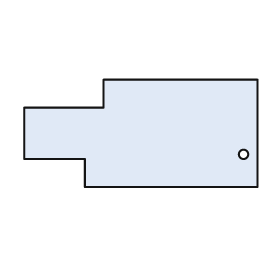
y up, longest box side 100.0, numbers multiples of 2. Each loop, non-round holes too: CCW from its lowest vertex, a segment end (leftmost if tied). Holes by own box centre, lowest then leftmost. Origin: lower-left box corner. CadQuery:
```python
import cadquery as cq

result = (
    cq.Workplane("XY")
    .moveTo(26.0, 0.0)
    .lineTo(100.0, 0.0)
    .lineTo(100.0, 46.0)
    .lineTo(34.0, 46.0)
    .lineTo(34.0, 34.0)
    .lineTo(0.0, 34.0)
    .lineTo(0.0, 12.0)
    .lineTo(26.0, 12.0)
    .close()
    .moveTo(94.0, 14.0)
    .circle(2.0)
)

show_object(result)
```